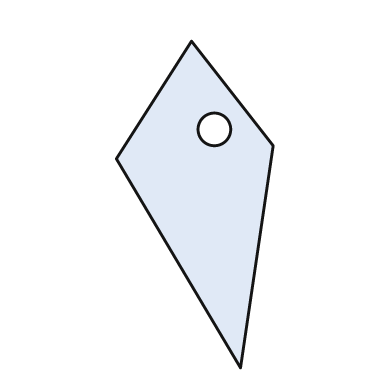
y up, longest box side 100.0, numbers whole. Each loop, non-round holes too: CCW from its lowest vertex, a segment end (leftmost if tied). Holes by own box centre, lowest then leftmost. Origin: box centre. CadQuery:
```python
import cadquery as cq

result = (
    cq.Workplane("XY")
    .moveTo(14.0, -50.0)
    .lineTo(24.0, 18.0)
    .lineTo(-1.0, 50.0)
    .lineTo(-24.0, 14.0)
    .close()
    .moveTo(6.0, 23.0)
    .circle(5.0)
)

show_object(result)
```